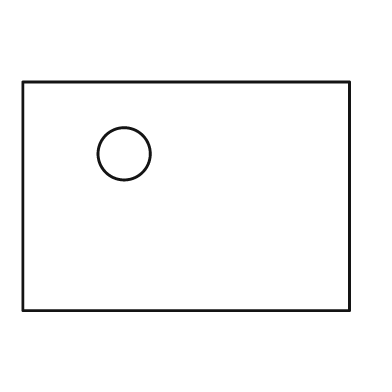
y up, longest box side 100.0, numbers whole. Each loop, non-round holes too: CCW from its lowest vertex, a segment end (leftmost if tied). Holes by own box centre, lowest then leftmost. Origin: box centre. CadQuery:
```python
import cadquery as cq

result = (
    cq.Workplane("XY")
    .moveTo(-50.0, -35.0)
    .lineTo(50.0, -35.0)
    .lineTo(50.0, 35.0)
    .lineTo(-50.0, 35.0)
    .close()
    .moveTo(-19.0, 13.0)
    .circle(8.0)
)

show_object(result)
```